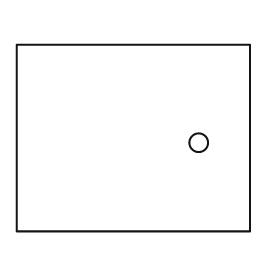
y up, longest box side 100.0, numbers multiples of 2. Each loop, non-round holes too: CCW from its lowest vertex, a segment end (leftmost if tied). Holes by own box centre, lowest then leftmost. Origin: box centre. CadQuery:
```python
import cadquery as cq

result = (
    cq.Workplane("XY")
    .moveTo(-50.0, -40.0)
    .lineTo(50.0, -40.0)
    .lineTo(50.0, 40.0)
    .lineTo(-50.0, 40.0)
    .close()
    .moveTo(28.0, -2.0)
    .circle(4.0)
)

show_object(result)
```